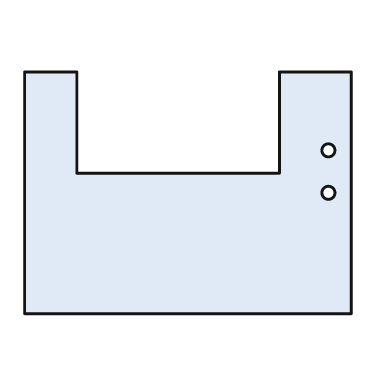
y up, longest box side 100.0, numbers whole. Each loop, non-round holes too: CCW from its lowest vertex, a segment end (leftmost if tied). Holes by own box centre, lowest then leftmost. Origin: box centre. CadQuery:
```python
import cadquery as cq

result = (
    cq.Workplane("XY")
    .moveTo(-50.0, -37.0)
    .lineTo(50.0, -37.0)
    .lineTo(50.0, 37.0)
    .lineTo(28.0, 37.0)
    .lineTo(28.0, 6.0)
    .lineTo(-34.0, 6.0)
    .lineTo(-34.0, 37.0)
    .lineTo(-50.0, 37.0)
    .close()
    .moveTo(43.0, 0.0)
    .circle(2.0)
    .moveTo(43.0, 13.0)
    .circle(2.0)
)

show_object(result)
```